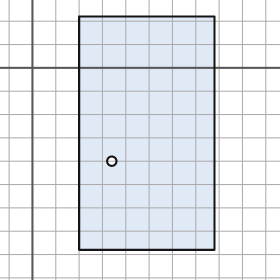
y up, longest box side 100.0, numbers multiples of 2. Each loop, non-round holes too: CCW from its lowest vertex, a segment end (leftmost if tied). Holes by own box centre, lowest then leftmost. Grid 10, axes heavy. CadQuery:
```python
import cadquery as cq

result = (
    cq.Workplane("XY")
    .moveTo(20.0, -78.0)
    .lineTo(78.0, -78.0)
    .lineTo(78.0, 22.0)
    .lineTo(20.0, 22.0)
    .close()
    .moveTo(34.0, -40.0)
    .circle(2.0)
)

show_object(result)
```